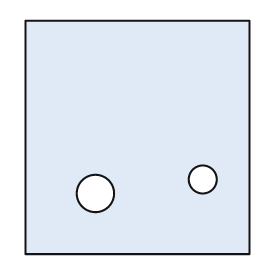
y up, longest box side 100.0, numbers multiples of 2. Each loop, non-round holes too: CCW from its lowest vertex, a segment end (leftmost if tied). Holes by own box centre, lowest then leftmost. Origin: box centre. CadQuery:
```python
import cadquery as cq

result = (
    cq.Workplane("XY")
    .moveTo(-48.0, -50.0)
    .lineTo(48.0, -50.0)
    .lineTo(48.0, 50.0)
    .lineTo(-48.0, 50.0)
    .close()
    .moveTo(-18.0, -24.0)
    .circle(8.0)
    .moveTo(28.0, -18.0)
    .circle(6.0)
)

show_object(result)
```